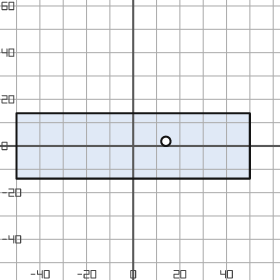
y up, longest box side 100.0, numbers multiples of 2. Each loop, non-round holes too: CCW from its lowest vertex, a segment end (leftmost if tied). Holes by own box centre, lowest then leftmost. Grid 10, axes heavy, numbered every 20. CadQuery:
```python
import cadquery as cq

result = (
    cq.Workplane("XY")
    .moveTo(-50.0, -14.0)
    .lineTo(50.0, -14.0)
    .lineTo(50.0, 14.0)
    .lineTo(-50.0, 14.0)
    .close()
    .moveTo(14.0, 2.0)
    .circle(2.0)
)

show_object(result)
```